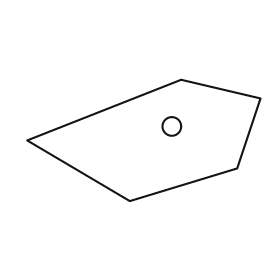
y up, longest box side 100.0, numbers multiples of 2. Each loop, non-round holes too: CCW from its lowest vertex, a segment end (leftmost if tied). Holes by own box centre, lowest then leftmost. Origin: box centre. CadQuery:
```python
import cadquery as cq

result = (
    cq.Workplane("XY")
    .moveTo(-6.0, -26.0)
    .lineTo(40.0, -12.0)
    .lineTo(50.0, 18.0)
    .lineTo(16.0, 26.0)
    .lineTo(-50.0, 0.0)
    .close()
    .moveTo(12.0, 6.0)
    .circle(4.0)
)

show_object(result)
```